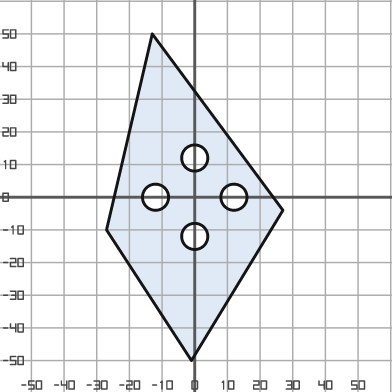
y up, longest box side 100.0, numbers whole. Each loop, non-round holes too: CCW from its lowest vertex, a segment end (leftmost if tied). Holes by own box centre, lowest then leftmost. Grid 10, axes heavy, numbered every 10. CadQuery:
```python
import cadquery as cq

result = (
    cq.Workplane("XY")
    .moveTo(-1.0, -50.0)
    .lineTo(27.0, -4.0)
    .lineTo(-13.0, 50.0)
    .lineTo(-27.0, -10.0)
    .close()
    .moveTo(0.0, -12.0)
    .circle(4.0)
    .moveTo(-12.0, 0.0)
    .circle(4.0)
    .moveTo(12.0, 0.0)
    .circle(4.0)
    .moveTo(0.0, 12.0)
    .circle(4.0)
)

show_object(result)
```